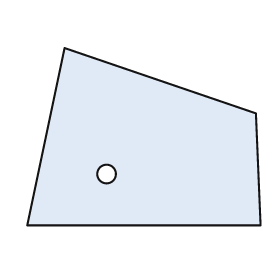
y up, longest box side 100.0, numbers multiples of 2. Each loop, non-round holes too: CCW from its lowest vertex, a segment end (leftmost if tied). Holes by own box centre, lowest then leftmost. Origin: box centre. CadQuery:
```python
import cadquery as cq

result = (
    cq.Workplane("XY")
    .moveTo(-50.0, -38.0)
    .lineTo(50.0, -38.0)
    .lineTo(48.0, 10.0)
    .lineTo(-34.0, 38.0)
    .close()
    .moveTo(-16.0, -16.0)
    .circle(4.0)
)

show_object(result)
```